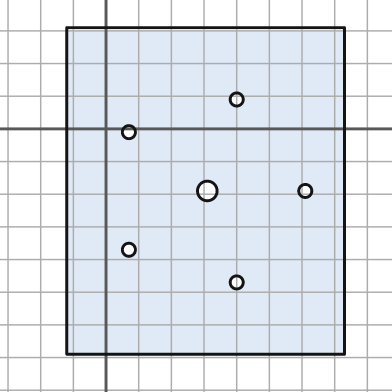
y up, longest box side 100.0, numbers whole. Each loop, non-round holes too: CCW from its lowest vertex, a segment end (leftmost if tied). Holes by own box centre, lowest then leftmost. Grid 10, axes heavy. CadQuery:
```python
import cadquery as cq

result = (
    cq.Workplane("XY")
    .moveTo(-12.0, -69.0)
    .lineTo(73.0, -69.0)
    .lineTo(73.0, 31.0)
    .lineTo(-12.0, 31.0)
    .close()
    .moveTo(40.0, -47.0)
    .circle(2.0)
    .moveTo(7.0, -37.0)
    .circle(2.0)
    .moveTo(31.0, -19.0)
    .circle(3.0)
    .moveTo(61.0, -19.0)
    .circle(2.0)
    .moveTo(7.0, -1.0)
    .circle(2.0)
    .moveTo(40.0, 9.0)
    .circle(2.0)
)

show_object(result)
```